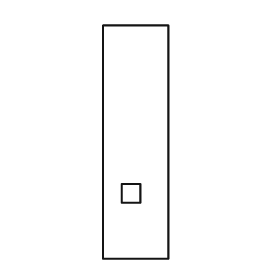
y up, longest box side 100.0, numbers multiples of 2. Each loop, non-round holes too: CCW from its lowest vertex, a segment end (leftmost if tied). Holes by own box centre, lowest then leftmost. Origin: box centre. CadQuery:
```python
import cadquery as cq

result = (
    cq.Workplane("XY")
    .moveTo(-14.0, -50.0)
    .lineTo(14.0, -50.0)
    .lineTo(14.0, 50.0)
    .lineTo(-14.0, 50.0)
    .close()
    .moveTo(-6.0, -26.0)
    .lineTo(2.0, -26.0)
    .lineTo(2.0, -18.0)
    .lineTo(-6.0, -18.0)
    .close()
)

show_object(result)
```